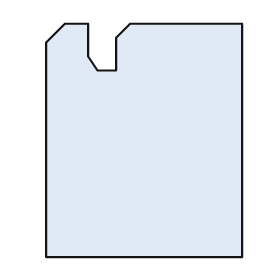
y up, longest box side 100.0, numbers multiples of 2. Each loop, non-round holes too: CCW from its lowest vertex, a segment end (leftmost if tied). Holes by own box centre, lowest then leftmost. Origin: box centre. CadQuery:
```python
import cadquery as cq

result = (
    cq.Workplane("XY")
    .moveTo(-42.0, -50.0)
    .lineTo(42.0, -50.0)
    .lineTo(42.0, 50.0)
    .lineTo(-6.0, 50.0)
    .lineTo(-12.0, 44.0)
    .lineTo(-12.0, 30.0)
    .lineTo(-20.0, 30.0)
    .lineTo(-24.0, 36.0)
    .lineTo(-24.0, 50.0)
    .lineTo(-34.0, 50.0)
    .lineTo(-42.0, 42.0)
    .close()
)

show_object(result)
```